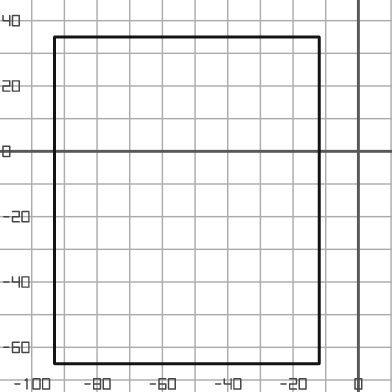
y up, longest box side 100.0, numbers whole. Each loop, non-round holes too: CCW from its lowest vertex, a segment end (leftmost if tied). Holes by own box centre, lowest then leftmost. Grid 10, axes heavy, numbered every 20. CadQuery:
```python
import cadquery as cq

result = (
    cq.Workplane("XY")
    .moveTo(-93.0, -65.0)
    .lineTo(-12.0, -65.0)
    .lineTo(-12.0, 35.0)
    .lineTo(-93.0, 35.0)
    .close()
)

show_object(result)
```